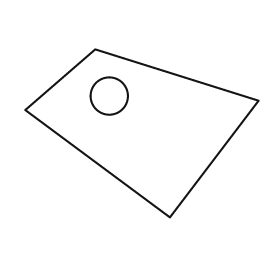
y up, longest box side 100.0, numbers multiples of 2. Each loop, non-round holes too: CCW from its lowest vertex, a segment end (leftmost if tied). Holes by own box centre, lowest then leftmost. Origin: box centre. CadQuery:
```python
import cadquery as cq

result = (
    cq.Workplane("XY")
    .moveTo(12.0, -36.0)
    .lineTo(50.0, 14.0)
    .lineTo(-20.0, 36.0)
    .lineTo(-50.0, 10.0)
    .close()
    .moveTo(-14.0, 16.0)
    .circle(8.0)
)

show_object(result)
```